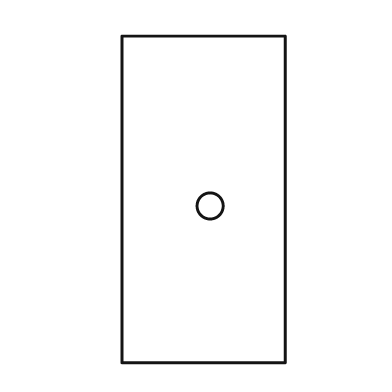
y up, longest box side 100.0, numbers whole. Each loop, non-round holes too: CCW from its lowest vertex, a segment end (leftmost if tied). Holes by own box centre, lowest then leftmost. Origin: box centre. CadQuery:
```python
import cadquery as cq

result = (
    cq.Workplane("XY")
    .moveTo(-25.0, -50.0)
    .lineTo(25.0, -50.0)
    .lineTo(25.0, 50.0)
    .lineTo(-25.0, 50.0)
    .close()
    .moveTo(2.0, -2.0)
    .circle(4.0)
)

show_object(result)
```